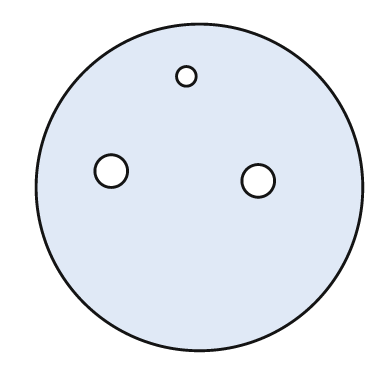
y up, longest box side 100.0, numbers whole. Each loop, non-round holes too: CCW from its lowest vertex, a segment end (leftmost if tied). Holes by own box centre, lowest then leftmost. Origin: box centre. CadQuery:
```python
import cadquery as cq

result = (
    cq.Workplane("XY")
    .moveTo(0.0, 0.0)
    .circle(50.0)
    .moveTo(18.0, 2.0)
    .circle(5.0)
    .moveTo(-27.0, 5.0)
    .circle(5.0)
    .moveTo(-4.0, 34.0)
    .circle(3.0)
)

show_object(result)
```